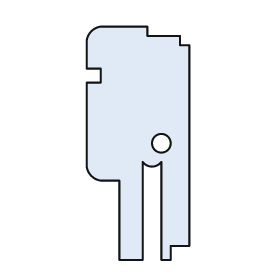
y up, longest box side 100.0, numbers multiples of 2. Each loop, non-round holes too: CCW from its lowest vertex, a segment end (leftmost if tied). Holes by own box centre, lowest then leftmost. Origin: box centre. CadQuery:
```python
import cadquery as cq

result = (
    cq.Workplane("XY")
    .moveTo(-8.0, -50.0)
    .lineTo(2.0, -50.0)
    .lineTo(2.0, -8.0)
    .threePointArc((6.0, -10.0), (10.0, -8.0))
    .lineTo(10.0, -50.0)
    .lineTo(14.0, -50.0)
    .lineTo(14.0, -44.0)
    .lineTo(22.0, -44.0)
    .lineTo(22.0, 42.0)
    .lineTo(18.0, 42.0)
    .lineTo(18.0, 46.0)
    .lineTo(4.0, 46.0)
    .lineTo(4.0, 50.0)
    .lineTo(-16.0, 50.0)
    .threePointArc((-20.0, 48.0), (-22.0, 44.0))
    .lineTo(-22.0, 32.0)
    .lineTo(-16.0, 32.0)
    .lineTo(-16.0, 26.0)
    .lineTo(-22.0, 26.0)
    .lineTo(-22.0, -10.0)
    .threePointArc((-20.0, -14.0), (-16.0, -16.0))
    .lineTo(-8.0, -16.0)
    .close()
    .moveTo(10.0, 0.0)
    .circle(4.0)
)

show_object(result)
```